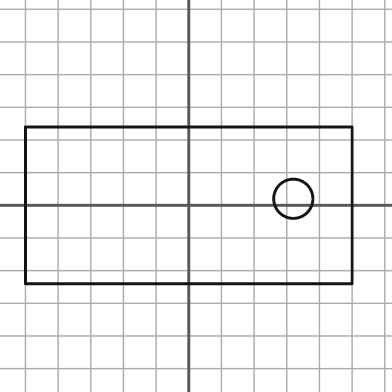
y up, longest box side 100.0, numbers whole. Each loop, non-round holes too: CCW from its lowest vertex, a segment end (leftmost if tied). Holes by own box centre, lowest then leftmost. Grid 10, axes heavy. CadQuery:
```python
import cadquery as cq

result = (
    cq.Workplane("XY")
    .moveTo(-50.0, -24.0)
    .lineTo(50.0, -24.0)
    .lineTo(50.0, 24.0)
    .lineTo(-50.0, 24.0)
    .close()
    .moveTo(32.0, 2.0)
    .circle(6.0)
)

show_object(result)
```